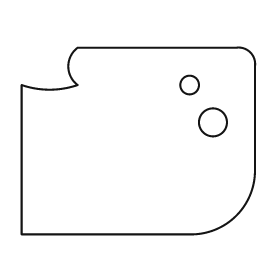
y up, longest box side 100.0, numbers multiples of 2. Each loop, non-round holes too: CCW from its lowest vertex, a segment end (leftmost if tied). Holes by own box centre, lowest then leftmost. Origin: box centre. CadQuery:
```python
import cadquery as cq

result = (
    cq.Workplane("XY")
    .moveTo(-50.0, -40.0)
    .lineTo(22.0, -40.0)
    .threePointArc((42.0, -32.0), (50.0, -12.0))
    .lineTo(50.0, 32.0)
    .threePointArc((48.0, 38.0), (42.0, 40.0))
    .lineTo(-26.0, 40.0)
    .threePointArc((-30.0, 32.0), (-26.0, 24.0))
    .threePointArc((-38.0, 22.0), (-50.0, 24.0))
    .close()
    .moveTo(32.0, 8.0)
    .circle(6.0)
    .moveTo(22.0, 24.0)
    .circle(4.0)
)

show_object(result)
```